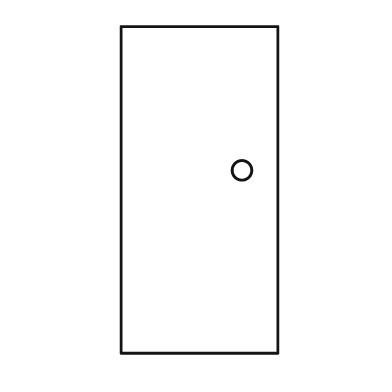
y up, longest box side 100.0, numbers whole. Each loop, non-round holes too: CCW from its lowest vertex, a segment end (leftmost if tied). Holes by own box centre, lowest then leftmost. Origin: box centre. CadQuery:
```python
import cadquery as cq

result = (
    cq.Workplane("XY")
    .moveTo(-24.0, -50.0)
    .lineTo(24.0, -50.0)
    .lineTo(24.0, 50.0)
    .lineTo(-24.0, 50.0)
    .close()
    .moveTo(13.0, 6.0)
    .circle(3.0)
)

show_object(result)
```